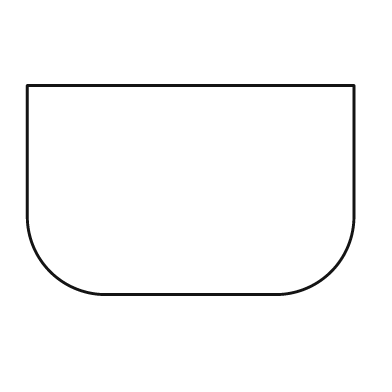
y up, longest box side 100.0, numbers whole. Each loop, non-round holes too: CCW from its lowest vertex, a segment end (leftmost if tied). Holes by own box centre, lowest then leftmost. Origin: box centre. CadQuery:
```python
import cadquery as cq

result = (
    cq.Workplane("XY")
    .moveTo(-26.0, -32.0)
    .lineTo(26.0, -32.0)
    .threePointArc((43.0, -25.0), (50.0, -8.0))
    .lineTo(50.0, 32.0)
    .lineTo(-50.0, 32.0)
    .lineTo(-50.0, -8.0)
    .threePointArc((-43.0, -25.0), (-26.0, -32.0))
    .close()
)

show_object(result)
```